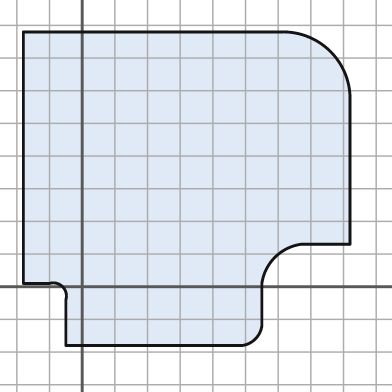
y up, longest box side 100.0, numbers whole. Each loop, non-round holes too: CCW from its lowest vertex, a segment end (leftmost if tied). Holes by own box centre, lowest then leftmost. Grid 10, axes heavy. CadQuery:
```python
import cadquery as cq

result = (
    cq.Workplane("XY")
    .moveTo(-5.0, -18.0)
    .lineTo(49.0, -18.0)
    .threePointArc((53.0, -16.0), (55.0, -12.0))
    .lineTo(55.0, 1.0)
    .threePointArc((59.0, 9.0), (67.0, 13.0))
    .lineTo(82.0, 13.0)
    .lineTo(82.0, 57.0)
    .threePointArc((76.0, 72.0), (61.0, 78.0))
    .lineTo(-18.0, 78.0)
    .lineTo(-18.0, 1.0)
    .lineTo(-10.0, 1.0)
    .threePointArc((-6.0, 0.0), (-5.0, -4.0))
    .close()
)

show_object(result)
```